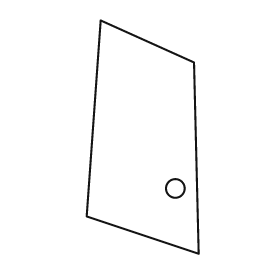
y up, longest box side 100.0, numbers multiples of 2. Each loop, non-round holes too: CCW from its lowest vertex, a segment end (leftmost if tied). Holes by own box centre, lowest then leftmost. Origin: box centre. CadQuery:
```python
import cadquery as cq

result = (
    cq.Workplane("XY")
    .moveTo(24.0, -50.0)
    .lineTo(22.0, 32.0)
    .lineTo(-18.0, 50.0)
    .lineTo(-24.0, -34.0)
    .close()
    .moveTo(14.0, -22.0)
    .circle(4.0)
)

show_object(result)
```